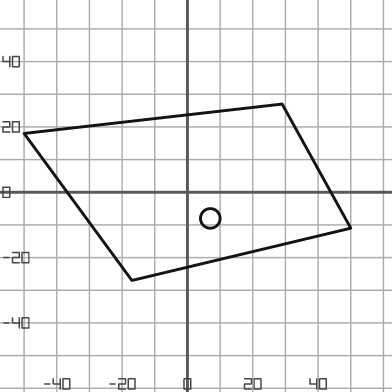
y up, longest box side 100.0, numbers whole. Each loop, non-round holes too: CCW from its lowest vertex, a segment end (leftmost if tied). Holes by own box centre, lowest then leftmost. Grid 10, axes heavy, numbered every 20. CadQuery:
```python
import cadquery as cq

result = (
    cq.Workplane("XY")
    .moveTo(-17.0, -27.0)
    .lineTo(50.0, -11.0)
    .lineTo(29.0, 27.0)
    .lineTo(-50.0, 18.0)
    .close()
    .moveTo(7.0, -8.0)
    .circle(3.0)
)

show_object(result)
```